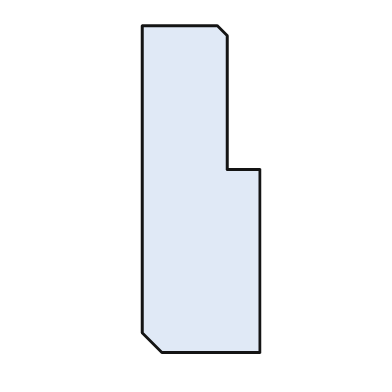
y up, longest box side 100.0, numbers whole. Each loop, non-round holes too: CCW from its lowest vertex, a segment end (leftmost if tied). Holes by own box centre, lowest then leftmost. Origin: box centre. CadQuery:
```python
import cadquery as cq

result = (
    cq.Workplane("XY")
    .moveTo(-12.0, -50.0)
    .lineTo(18.0, -50.0)
    .lineTo(18.0, 6.0)
    .lineTo(8.0, 6.0)
    .lineTo(8.0, 47.0)
    .lineTo(5.0, 50.0)
    .lineTo(-18.0, 50.0)
    .lineTo(-18.0, -44.0)
    .close()
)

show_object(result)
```